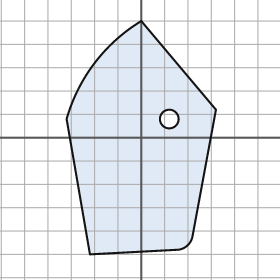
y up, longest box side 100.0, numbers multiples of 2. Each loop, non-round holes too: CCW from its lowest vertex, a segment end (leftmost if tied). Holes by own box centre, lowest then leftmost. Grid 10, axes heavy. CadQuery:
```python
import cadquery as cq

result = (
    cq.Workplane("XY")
    .moveTo(-22.0, -50.0)
    .lineTo(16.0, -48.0)
    .threePointArc((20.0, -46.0), (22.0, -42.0))
    .lineTo(32.0, 12.0)
    .lineTo(0.0, 50.0)
    .threePointArc((-20.0, 32.0), (-32.0, 8.0))
    .close()
    .moveTo(12.0, 8.0)
    .circle(4.0)
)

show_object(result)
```